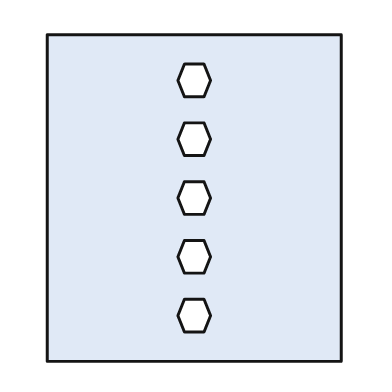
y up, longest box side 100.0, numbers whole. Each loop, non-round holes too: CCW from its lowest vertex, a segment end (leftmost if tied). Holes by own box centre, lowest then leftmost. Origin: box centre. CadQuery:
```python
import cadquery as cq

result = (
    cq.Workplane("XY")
    .moveTo(-45.0, -50.0)
    .lineTo(45.0, -50.0)
    .lineTo(45.0, 50.0)
    .lineTo(-45.0, 50.0)
    .close()
    .moveTo(-3.0, -41.0)
    .lineTo(3.0, -41.0)
    .lineTo(5.0, -36.0)
    .lineTo(3.0, -31.0)
    .lineTo(-3.0, -31.0)
    .lineTo(-5.0, -36.0)
    .close()
    .moveTo(-3.0, -23.0)
    .lineTo(3.0, -23.0)
    .lineTo(5.0, -18.0)
    .lineTo(3.0, -13.0)
    .lineTo(-3.0, -13.0)
    .lineTo(-5.0, -18.0)
    .close()
    .moveTo(-3.0, -5.0)
    .lineTo(3.0, -5.0)
    .lineTo(5.0, 0.0)
    .lineTo(3.0, 5.0)
    .lineTo(-3.0, 5.0)
    .lineTo(-5.0, 0.0)
    .close()
    .moveTo(-3.0, 13.0)
    .lineTo(3.0, 13.0)
    .lineTo(5.0, 18.0)
    .lineTo(3.0, 23.0)
    .lineTo(-3.0, 23.0)
    .lineTo(-5.0, 18.0)
    .close()
    .moveTo(-3.0, 31.0)
    .lineTo(3.0, 31.0)
    .lineTo(5.0, 36.0)
    .lineTo(3.0, 41.0)
    .lineTo(-3.0, 41.0)
    .lineTo(-5.0, 36.0)
    .close()
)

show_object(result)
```